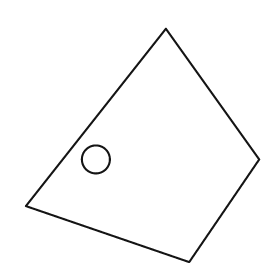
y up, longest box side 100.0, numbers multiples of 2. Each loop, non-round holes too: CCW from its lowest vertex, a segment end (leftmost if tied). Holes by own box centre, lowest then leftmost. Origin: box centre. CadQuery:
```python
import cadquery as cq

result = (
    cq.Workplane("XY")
    .moveTo(20.0, -50.0)
    .lineTo(50.0, -6.0)
    .lineTo(10.0, 50.0)
    .lineTo(-50.0, -26.0)
    .close()
    .moveTo(-20.0, -6.0)
    .circle(6.0)
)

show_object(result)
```